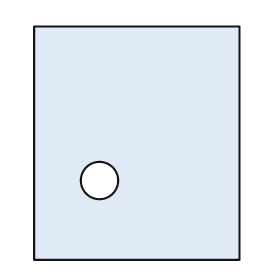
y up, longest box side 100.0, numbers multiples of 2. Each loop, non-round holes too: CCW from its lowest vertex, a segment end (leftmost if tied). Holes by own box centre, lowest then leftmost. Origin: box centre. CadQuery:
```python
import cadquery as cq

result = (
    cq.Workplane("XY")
    .moveTo(-44.0, -50.0)
    .lineTo(44.0, -50.0)
    .lineTo(44.0, 50.0)
    .lineTo(-44.0, 50.0)
    .close()
    .moveTo(-16.0, -16.0)
    .circle(8.0)
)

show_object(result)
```